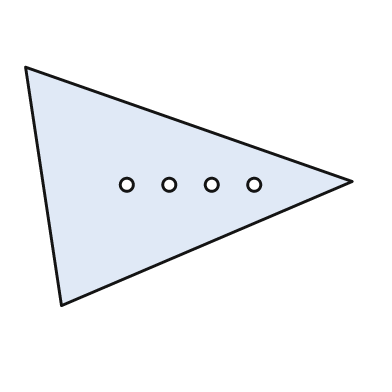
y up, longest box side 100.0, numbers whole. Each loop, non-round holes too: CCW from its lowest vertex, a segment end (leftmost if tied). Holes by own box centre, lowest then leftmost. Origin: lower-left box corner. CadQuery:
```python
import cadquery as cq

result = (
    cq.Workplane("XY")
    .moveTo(11.0, 0.0)
    .lineTo(100.0, 38.0)
    .lineTo(0.0, 73.0)
    .close()
    .moveTo(31.0, 37.0)
    .circle(2.0)
    .moveTo(44.0, 37.0)
    .circle(2.0)
    .moveTo(57.0, 37.0)
    .circle(2.0)
    .moveTo(70.0, 37.0)
    .circle(2.0)
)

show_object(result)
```